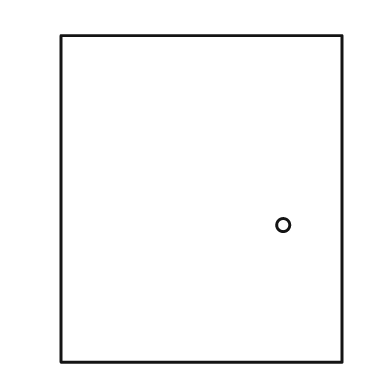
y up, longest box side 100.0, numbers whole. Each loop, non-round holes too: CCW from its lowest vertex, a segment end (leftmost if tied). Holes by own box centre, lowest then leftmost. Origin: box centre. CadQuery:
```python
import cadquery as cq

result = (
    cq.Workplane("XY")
    .moveTo(-43.0, -50.0)
    .lineTo(43.0, -50.0)
    .lineTo(43.0, 50.0)
    .lineTo(-43.0, 50.0)
    .close()
    .moveTo(25.0, -8.0)
    .circle(2.0)
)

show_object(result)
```